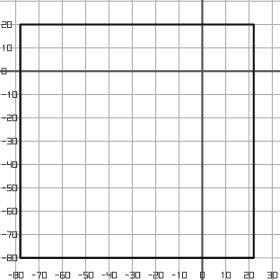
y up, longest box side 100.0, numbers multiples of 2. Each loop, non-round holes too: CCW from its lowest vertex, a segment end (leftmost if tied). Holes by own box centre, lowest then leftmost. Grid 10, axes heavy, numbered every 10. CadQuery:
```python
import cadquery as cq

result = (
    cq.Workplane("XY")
    .moveTo(-78.0, -80.0)
    .lineTo(22.0, -80.0)
    .lineTo(22.0, 20.0)
    .lineTo(-78.0, 20.0)
    .close()
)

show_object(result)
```